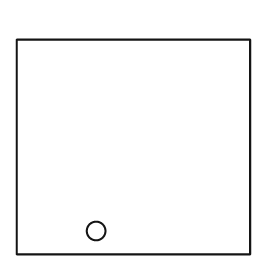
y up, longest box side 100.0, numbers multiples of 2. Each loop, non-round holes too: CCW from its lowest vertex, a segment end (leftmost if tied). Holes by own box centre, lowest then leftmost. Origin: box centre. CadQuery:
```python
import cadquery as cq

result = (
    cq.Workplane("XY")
    .moveTo(-50.0, -46.0)
    .lineTo(50.0, -46.0)
    .lineTo(50.0, 46.0)
    .lineTo(-50.0, 46.0)
    .close()
    .moveTo(-16.0, -36.0)
    .circle(4.0)
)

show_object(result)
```